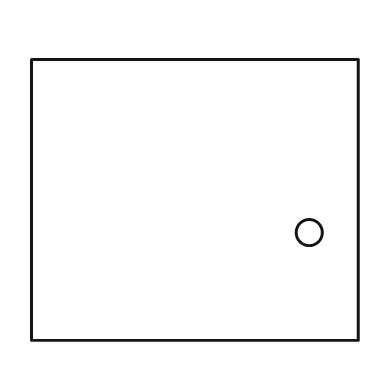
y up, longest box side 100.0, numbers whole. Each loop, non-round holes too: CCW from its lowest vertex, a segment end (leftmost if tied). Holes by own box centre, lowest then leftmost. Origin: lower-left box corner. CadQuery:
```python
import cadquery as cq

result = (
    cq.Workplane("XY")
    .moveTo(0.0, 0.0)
    .lineTo(100.0, 0.0)
    .lineTo(100.0, 86.0)
    .lineTo(0.0, 86.0)
    .close()
    .moveTo(85.0, 33.0)
    .circle(4.0)
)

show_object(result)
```